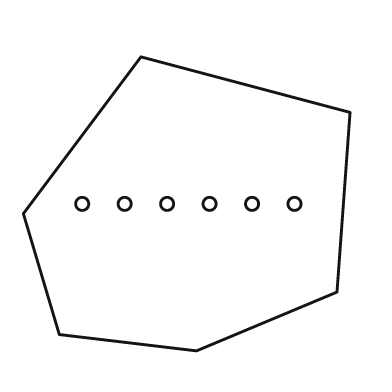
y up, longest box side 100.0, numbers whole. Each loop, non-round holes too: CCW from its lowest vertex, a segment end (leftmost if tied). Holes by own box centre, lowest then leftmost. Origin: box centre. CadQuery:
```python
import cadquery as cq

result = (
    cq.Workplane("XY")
    .moveTo(3.0, -45.0)
    .lineTo(46.0, -27.0)
    .lineTo(50.0, 28.0)
    .lineTo(-14.0, 45.0)
    .lineTo(-50.0, -3.0)
    .lineTo(-39.0, -40.0)
    .close()
    .moveTo(-32.0, 0.0)
    .circle(2.0)
    .moveTo(-19.0, 0.0)
    .circle(2.0)
    .moveTo(-6.0, 0.0)
    .circle(2.0)
    .moveTo(7.0, 0.0)
    .circle(2.0)
    .moveTo(20.0, 0.0)
    .circle(2.0)
    .moveTo(33.0, 0.0)
    .circle(2.0)
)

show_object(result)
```